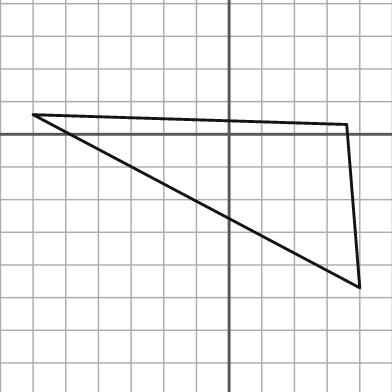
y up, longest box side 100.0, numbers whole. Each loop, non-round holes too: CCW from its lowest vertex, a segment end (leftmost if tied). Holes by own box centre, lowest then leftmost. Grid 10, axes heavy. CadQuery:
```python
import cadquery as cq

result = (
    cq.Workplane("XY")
    .moveTo(40.0, -47.0)
    .lineTo(36.0, 3.0)
    .lineTo(-60.0, 6.0)
    .close()
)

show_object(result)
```